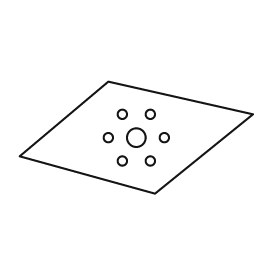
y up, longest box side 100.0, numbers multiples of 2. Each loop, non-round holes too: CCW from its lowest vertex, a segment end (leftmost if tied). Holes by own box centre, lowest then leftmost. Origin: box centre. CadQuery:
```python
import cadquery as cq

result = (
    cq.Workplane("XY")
    .moveTo(8.0, -24.0)
    .lineTo(50.0, 10.0)
    .lineTo(-12.0, 24.0)
    .lineTo(-50.0, -8.0)
    .close()
    .moveTo(-6.0, -10.0)
    .circle(2.0)
    .moveTo(6.0, -10.0)
    .circle(2.0)
    .moveTo(-12.0, 0.0)
    .circle(2.0)
    .moveTo(0.0, 0.0)
    .circle(4.0)
    .moveTo(12.0, 0.0)
    .circle(2.0)
    .moveTo(-6.0, 10.0)
    .circle(2.0)
    .moveTo(6.0, 10.0)
    .circle(2.0)
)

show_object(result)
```